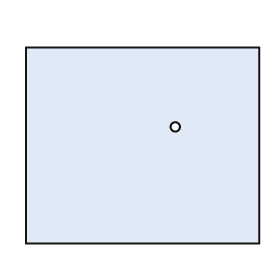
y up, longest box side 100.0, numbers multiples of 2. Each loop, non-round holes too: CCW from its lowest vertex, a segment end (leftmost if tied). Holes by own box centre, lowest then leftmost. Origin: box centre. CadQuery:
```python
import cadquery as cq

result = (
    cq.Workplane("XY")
    .moveTo(-50.0, -42.0)
    .lineTo(50.0, -42.0)
    .lineTo(50.0, 42.0)
    .lineTo(-50.0, 42.0)
    .close()
    .moveTo(14.0, 8.0)
    .circle(2.0)
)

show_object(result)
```